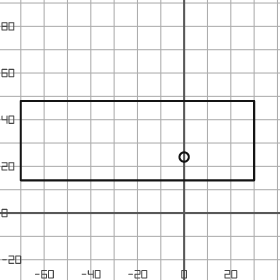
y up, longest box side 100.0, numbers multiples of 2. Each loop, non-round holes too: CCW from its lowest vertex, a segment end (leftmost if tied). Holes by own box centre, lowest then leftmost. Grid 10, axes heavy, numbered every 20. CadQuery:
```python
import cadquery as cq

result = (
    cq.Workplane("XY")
    .moveTo(-70.0, 14.0)
    .lineTo(30.0, 14.0)
    .lineTo(30.0, 48.0)
    .lineTo(-70.0, 48.0)
    .close()
    .moveTo(0.0, 24.0)
    .circle(2.0)
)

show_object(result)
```